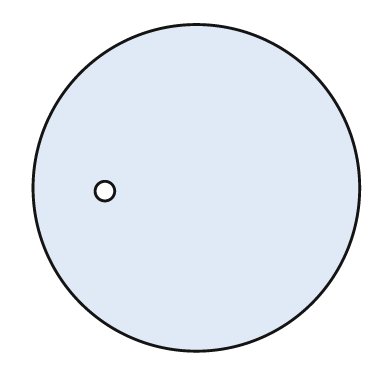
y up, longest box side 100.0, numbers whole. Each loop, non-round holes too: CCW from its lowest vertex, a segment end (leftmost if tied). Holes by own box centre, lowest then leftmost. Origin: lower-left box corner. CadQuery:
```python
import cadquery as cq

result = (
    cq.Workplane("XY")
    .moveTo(50.0, 50.0)
    .circle(50.0)
    .moveTo(22.0, 49.0)
    .circle(3.0)
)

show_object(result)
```